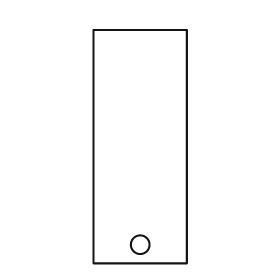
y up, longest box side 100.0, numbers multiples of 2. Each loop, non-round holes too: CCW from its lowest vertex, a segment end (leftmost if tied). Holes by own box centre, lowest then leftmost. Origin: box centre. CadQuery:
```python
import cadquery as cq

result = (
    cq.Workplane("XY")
    .moveTo(-20.0, -50.0)
    .lineTo(20.0, -50.0)
    .lineTo(20.0, 50.0)
    .lineTo(-20.0, 50.0)
    .close()
    .moveTo(0.0, -42.0)
    .circle(4.0)
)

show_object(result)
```